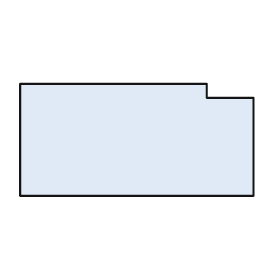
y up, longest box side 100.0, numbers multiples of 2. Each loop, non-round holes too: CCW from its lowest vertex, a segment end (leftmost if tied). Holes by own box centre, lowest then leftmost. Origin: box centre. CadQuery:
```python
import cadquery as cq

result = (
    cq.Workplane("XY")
    .moveTo(-50.0, -24.0)
    .lineTo(50.0, -24.0)
    .lineTo(50.0, 18.0)
    .lineTo(30.0, 18.0)
    .lineTo(30.0, 24.0)
    .lineTo(-50.0, 24.0)
    .close()
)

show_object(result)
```